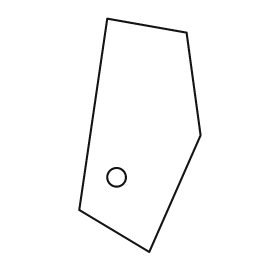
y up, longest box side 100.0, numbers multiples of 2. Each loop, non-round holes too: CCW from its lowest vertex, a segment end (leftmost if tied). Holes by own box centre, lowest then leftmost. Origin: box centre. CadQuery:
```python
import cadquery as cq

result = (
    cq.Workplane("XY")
    .moveTo(4.0, -50.0)
    .lineTo(26.0, 0.0)
    .lineTo(20.0, 44.0)
    .lineTo(-14.0, 50.0)
    .lineTo(-26.0, -32.0)
    .close()
    .moveTo(-10.0, -18.0)
    .circle(4.0)
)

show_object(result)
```